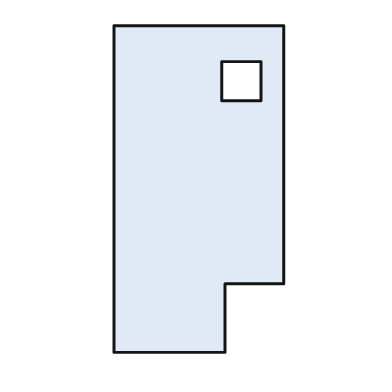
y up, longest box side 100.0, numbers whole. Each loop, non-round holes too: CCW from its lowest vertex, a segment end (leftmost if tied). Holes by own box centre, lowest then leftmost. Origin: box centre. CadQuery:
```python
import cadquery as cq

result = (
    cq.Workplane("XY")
    .moveTo(-26.0, -50.0)
    .lineTo(8.0, -50.0)
    .lineTo(8.0, -29.0)
    .lineTo(26.0, -29.0)
    .lineTo(26.0, 50.0)
    .lineTo(-26.0, 50.0)
    .close()
    .moveTo(7.0, 27.0)
    .lineTo(19.0, 27.0)
    .lineTo(19.0, 39.0)
    .lineTo(7.0, 39.0)
    .close()
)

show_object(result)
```